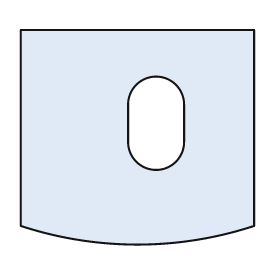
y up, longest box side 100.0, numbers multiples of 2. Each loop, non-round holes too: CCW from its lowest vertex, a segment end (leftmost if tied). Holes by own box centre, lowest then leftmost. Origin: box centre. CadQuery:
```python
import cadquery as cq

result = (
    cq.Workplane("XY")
    .moveTo(-50.0, -38.0)
    .threePointArc((0.0, -46.0), (50.0, -38.0))
    .lineTo(50.0, 46.0)
    .lineTo(-50.0, 46.0)
    .close()
    .moveTo(-4.0, -2.0)
    .threePointArc((8.0, -14.0), (20.0, -2.0))
    .lineTo(20.0, 14.0)
    .threePointArc((8.0, 26.0), (-4.0, 14.0))
    .close()
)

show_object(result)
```